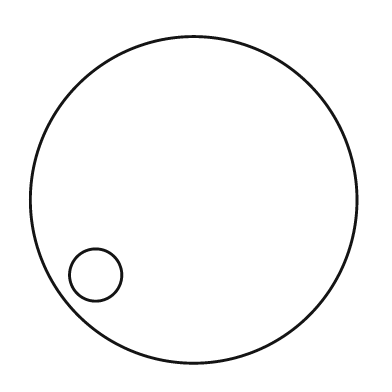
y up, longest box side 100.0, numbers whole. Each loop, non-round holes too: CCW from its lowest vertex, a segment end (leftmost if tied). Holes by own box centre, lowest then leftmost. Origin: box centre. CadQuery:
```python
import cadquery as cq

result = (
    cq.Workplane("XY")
    .moveTo(0.0, 0.0)
    .circle(50.0)
    .moveTo(-30.0, -23.0)
    .circle(8.0)
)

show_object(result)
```